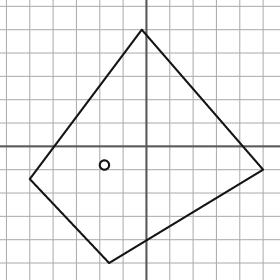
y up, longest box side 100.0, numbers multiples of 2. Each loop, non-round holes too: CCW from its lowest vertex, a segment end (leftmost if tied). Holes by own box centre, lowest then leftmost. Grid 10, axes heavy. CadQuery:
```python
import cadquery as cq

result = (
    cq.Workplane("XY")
    .moveTo(-16.0, -50.0)
    .lineTo(50.0, -10.0)
    .lineTo(-2.0, 50.0)
    .lineTo(-50.0, -14.0)
    .close()
    .moveTo(-18.0, -8.0)
    .circle(2.0)
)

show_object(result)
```